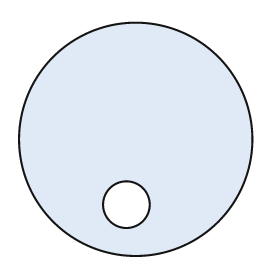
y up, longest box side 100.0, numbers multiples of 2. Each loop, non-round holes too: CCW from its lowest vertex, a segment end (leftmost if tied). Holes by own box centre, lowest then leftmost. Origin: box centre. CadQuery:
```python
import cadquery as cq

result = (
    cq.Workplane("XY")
    .moveTo(0.0, 0.0)
    .circle(50.0)
    .moveTo(-4.0, -28.0)
    .circle(10.0)
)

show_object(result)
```